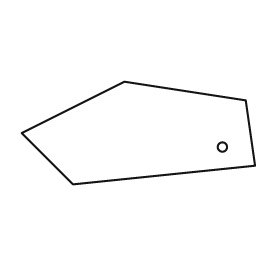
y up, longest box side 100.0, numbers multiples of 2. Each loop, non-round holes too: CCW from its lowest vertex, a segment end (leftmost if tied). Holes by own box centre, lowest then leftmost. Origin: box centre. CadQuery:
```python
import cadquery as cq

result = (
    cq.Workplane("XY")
    .moveTo(-28.0, -22.0)
    .lineTo(50.0, -14.0)
    .lineTo(46.0, 14.0)
    .lineTo(-6.0, 22.0)
    .lineTo(-50.0, 0.0)
    .close()
    .moveTo(36.0, -6.0)
    .circle(2.0)
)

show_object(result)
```